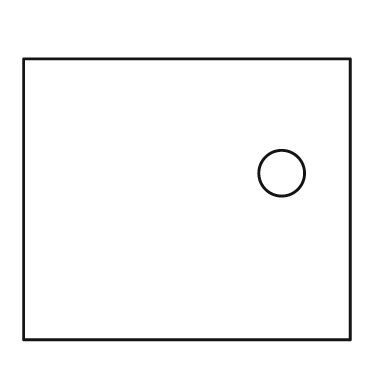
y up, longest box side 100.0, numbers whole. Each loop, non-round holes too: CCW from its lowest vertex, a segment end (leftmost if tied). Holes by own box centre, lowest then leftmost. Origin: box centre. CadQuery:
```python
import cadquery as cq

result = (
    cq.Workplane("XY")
    .moveTo(-50.0, -43.0)
    .lineTo(50.0, -43.0)
    .lineTo(50.0, 43.0)
    .lineTo(-50.0, 43.0)
    .close()
    .moveTo(29.0, 8.0)
    .circle(7.0)
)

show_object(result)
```